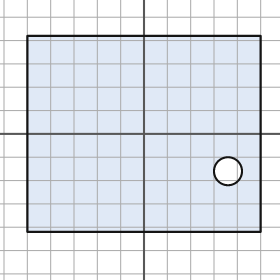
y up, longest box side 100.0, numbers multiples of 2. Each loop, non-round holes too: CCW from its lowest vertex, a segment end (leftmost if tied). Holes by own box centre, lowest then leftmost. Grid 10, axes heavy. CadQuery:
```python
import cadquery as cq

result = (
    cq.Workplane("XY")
    .moveTo(-50.0, -42.0)
    .lineTo(50.0, -42.0)
    .lineTo(50.0, 42.0)
    .lineTo(-50.0, 42.0)
    .close()
    .moveTo(36.0, -16.0)
    .circle(6.0)
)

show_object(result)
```